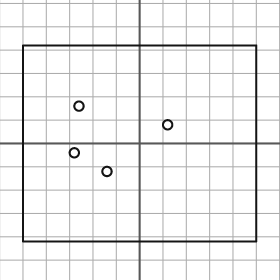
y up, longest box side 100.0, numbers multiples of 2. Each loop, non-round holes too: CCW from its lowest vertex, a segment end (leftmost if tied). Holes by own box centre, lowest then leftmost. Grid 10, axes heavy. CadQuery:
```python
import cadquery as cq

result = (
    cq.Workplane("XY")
    .moveTo(-50.0, -42.0)
    .lineTo(50.0, -42.0)
    .lineTo(50.0, 42.0)
    .lineTo(-50.0, 42.0)
    .close()
    .moveTo(-14.0, -12.0)
    .circle(2.0)
    .moveTo(-28.0, -4.0)
    .circle(2.0)
    .moveTo(12.0, 8.0)
    .circle(2.0)
    .moveTo(-26.0, 16.0)
    .circle(2.0)
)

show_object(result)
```